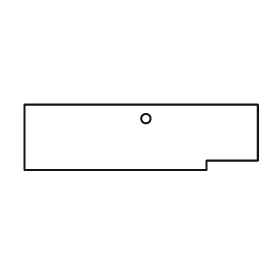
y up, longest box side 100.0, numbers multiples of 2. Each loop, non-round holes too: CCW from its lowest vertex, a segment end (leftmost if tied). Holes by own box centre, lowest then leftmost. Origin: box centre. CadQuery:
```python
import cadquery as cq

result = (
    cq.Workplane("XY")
    .moveTo(-50.0, -14.0)
    .lineTo(28.0, -14.0)
    .lineTo(28.0, -10.0)
    .lineTo(50.0, -10.0)
    .lineTo(50.0, 14.0)
    .lineTo(-50.0, 14.0)
    .close()
    .moveTo(2.0, 8.0)
    .circle(2.0)
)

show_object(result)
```